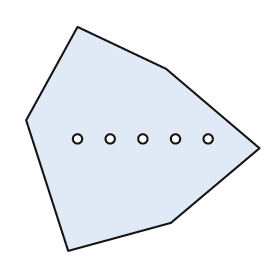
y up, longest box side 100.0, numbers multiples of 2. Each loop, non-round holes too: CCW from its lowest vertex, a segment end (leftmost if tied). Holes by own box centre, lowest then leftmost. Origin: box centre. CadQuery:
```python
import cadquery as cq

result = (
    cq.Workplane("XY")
    .moveTo(-32.0, -48.0)
    .lineTo(12.0, -36.0)
    .lineTo(50.0, -4.0)
    .lineTo(10.0, 30.0)
    .lineTo(-28.0, 48.0)
    .lineTo(-50.0, 8.0)
    .close()
    .moveTo(-28.0, 0.0)
    .circle(2.0)
    .moveTo(-14.0, 0.0)
    .circle(2.0)
    .moveTo(0.0, 0.0)
    .circle(2.0)
    .moveTo(14.0, 0.0)
    .circle(2.0)
    .moveTo(28.0, 0.0)
    .circle(2.0)
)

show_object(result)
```